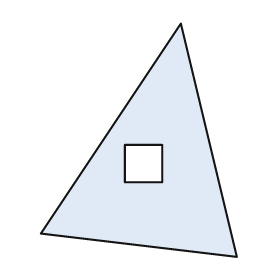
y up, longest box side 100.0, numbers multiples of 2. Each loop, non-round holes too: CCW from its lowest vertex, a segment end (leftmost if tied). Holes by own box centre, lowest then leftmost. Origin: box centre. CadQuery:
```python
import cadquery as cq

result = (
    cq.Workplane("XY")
    .moveTo(42.0, -50.0)
    .lineTo(18.0, 50.0)
    .lineTo(-42.0, -40.0)
    .close()
    .moveTo(-6.0, -18.0)
    .lineTo(10.0, -18.0)
    .lineTo(10.0, -2.0)
    .lineTo(-6.0, -2.0)
    .close()
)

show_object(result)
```